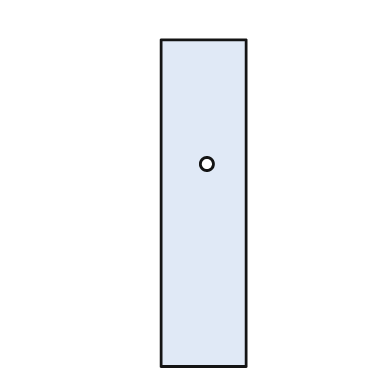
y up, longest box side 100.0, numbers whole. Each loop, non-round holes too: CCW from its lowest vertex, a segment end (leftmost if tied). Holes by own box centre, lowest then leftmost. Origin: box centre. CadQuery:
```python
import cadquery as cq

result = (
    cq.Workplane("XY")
    .moveTo(-13.0, -50.0)
    .lineTo(13.0, -50.0)
    .lineTo(13.0, 50.0)
    .lineTo(-13.0, 50.0)
    .close()
    .moveTo(1.0, 12.0)
    .circle(2.0)
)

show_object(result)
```